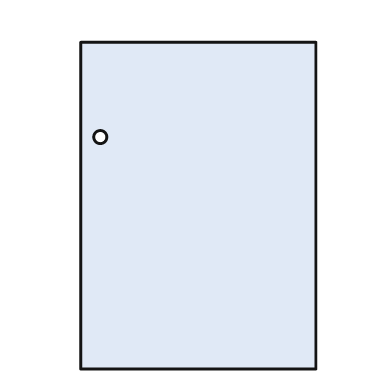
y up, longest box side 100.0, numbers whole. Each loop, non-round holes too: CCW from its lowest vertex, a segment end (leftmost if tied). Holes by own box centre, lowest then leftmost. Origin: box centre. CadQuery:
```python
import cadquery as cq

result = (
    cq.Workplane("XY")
    .moveTo(-36.0, -50.0)
    .lineTo(36.0, -50.0)
    .lineTo(36.0, 50.0)
    .lineTo(-36.0, 50.0)
    .close()
    .moveTo(-30.0, 21.0)
    .circle(2.0)
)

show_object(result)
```